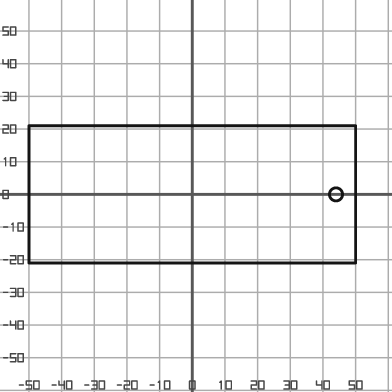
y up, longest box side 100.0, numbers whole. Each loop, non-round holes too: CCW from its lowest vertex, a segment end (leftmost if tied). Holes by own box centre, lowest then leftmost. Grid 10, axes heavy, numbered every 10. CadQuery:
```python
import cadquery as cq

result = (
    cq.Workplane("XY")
    .moveTo(-50.0, -21.0)
    .lineTo(50.0, -21.0)
    .lineTo(50.0, 21.0)
    .lineTo(-50.0, 21.0)
    .close()
    .moveTo(44.0, 0.0)
    .circle(2.0)
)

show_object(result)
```